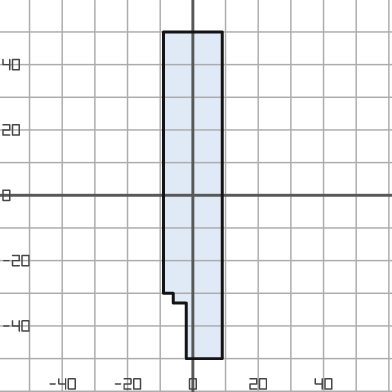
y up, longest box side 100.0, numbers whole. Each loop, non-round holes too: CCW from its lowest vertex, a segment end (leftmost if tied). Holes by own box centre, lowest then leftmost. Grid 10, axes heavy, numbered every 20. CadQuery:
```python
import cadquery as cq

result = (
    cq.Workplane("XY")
    .moveTo(-2.0, -50.0)
    .lineTo(9.0, -50.0)
    .lineTo(9.0, 50.0)
    .lineTo(-9.0, 50.0)
    .lineTo(-9.0, -30.0)
    .lineTo(-6.0, -30.0)
    .lineTo(-6.0, -33.0)
    .lineTo(-2.0, -33.0)
    .close()
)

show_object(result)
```